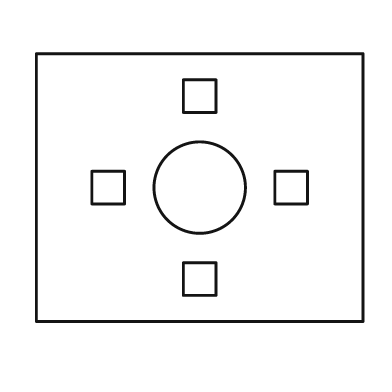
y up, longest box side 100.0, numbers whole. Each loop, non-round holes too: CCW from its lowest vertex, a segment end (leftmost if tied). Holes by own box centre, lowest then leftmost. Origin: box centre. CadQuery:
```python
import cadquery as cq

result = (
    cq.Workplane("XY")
    .moveTo(-50.0, -41.0)
    .lineTo(50.0, -41.0)
    .lineTo(50.0, 41.0)
    .lineTo(-50.0, 41.0)
    .close()
    .moveTo(-5.0, -33.0)
    .lineTo(5.0, -33.0)
    .lineTo(5.0, -23.0)
    .lineTo(-5.0, -23.0)
    .close()
    .moveTo(-33.0, -5.0)
    .lineTo(-23.0, -5.0)
    .lineTo(-23.0, 5.0)
    .lineTo(-33.0, 5.0)
    .close()
    .moveTo(0.0, 0.0)
    .circle(14.0)
    .moveTo(23.0, -5.0)
    .lineTo(33.0, -5.0)
    .lineTo(33.0, 5.0)
    .lineTo(23.0, 5.0)
    .close()
    .moveTo(-5.0, 23.0)
    .lineTo(5.0, 23.0)
    .lineTo(5.0, 33.0)
    .lineTo(-5.0, 33.0)
    .close()
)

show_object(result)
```